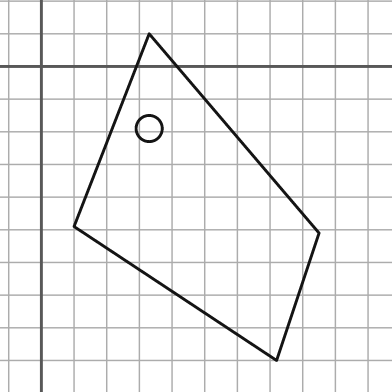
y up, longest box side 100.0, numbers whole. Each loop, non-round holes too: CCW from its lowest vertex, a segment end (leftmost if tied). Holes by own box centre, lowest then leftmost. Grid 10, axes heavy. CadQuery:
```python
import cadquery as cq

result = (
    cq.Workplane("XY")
    .moveTo(72.0, -90.0)
    .lineTo(85.0, -51.0)
    .lineTo(33.0, 10.0)
    .lineTo(10.0, -49.0)
    .close()
    .moveTo(33.0, -19.0)
    .circle(4.0)
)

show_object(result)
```